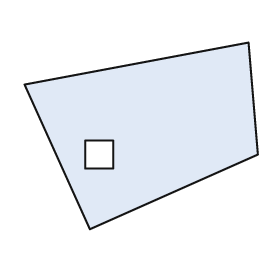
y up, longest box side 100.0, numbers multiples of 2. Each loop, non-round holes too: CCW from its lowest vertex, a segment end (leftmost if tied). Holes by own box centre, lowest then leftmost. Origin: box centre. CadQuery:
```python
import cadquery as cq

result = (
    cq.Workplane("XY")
    .moveTo(-22.0, -40.0)
    .lineTo(50.0, -8.0)
    .lineTo(46.0, 40.0)
    .lineTo(-50.0, 22.0)
    .close()
    .moveTo(-24.0, -14.0)
    .lineTo(-12.0, -14.0)
    .lineTo(-12.0, -2.0)
    .lineTo(-24.0, -2.0)
    .close()
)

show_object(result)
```